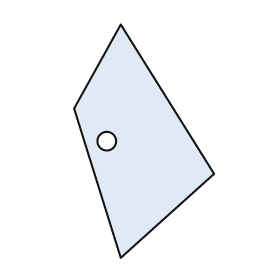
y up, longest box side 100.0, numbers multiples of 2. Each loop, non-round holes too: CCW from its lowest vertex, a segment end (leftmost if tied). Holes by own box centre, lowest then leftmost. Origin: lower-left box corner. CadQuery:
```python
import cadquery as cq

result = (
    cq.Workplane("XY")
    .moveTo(20.0, 0.0)
    .lineTo(60.0, 36.0)
    .lineTo(20.0, 100.0)
    .lineTo(0.0, 64.0)
    .close()
    .moveTo(14.0, 50.0)
    .circle(4.0)
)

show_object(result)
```